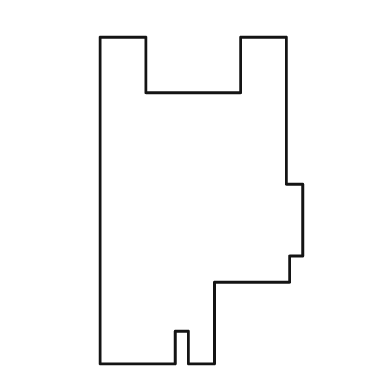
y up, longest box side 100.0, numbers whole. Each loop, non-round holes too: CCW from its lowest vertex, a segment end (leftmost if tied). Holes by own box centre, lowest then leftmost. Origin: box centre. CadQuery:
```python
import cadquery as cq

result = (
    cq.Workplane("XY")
    .moveTo(-31.0, -50.0)
    .lineTo(-8.0, -50.0)
    .lineTo(-8.0, -40.0)
    .lineTo(-4.0, -40.0)
    .lineTo(-4.0, -50.0)
    .lineTo(4.0, -50.0)
    .lineTo(4.0, -25.0)
    .lineTo(27.0, -25.0)
    .lineTo(27.0, -17.0)
    .lineTo(31.0, -17.0)
    .lineTo(31.0, 5.0)
    .lineTo(26.0, 5.0)
    .lineTo(26.0, 50.0)
    .lineTo(12.0, 50.0)
    .lineTo(12.0, 33.0)
    .lineTo(-17.0, 33.0)
    .lineTo(-17.0, 50.0)
    .lineTo(-31.0, 50.0)
    .close()
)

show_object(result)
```